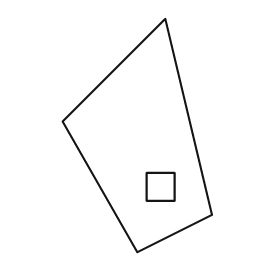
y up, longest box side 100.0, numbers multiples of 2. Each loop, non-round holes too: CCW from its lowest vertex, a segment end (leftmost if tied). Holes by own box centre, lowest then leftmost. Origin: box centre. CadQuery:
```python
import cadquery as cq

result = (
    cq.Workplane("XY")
    .moveTo(0.0, -50.0)
    .lineTo(32.0, -34.0)
    .lineTo(12.0, 50.0)
    .lineTo(-32.0, 6.0)
    .close()
    .moveTo(4.0, -28.0)
    .lineTo(16.0, -28.0)
    .lineTo(16.0, -16.0)
    .lineTo(4.0, -16.0)
    .close()
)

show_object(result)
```